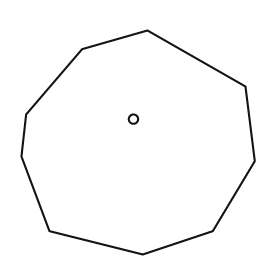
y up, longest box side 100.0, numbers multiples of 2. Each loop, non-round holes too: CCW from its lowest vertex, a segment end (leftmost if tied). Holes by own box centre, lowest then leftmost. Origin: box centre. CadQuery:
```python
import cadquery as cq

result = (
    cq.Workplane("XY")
    .moveTo(2.0, -48.0)
    .lineTo(32.0, -38.0)
    .lineTo(50.0, -8.0)
    .lineTo(46.0, 24.0)
    .lineTo(4.0, 48.0)
    .lineTo(-24.0, 40.0)
    .lineTo(-48.0, 12.0)
    .lineTo(-50.0, -6.0)
    .lineTo(-38.0, -38.0)
    .close()
    .moveTo(-2.0, 10.0)
    .circle(2.0)
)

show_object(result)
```